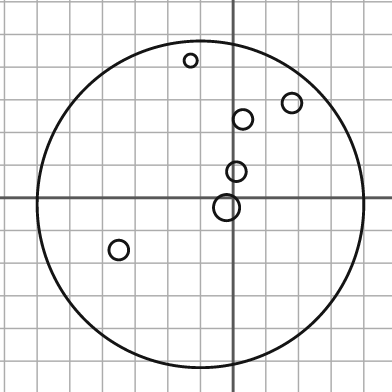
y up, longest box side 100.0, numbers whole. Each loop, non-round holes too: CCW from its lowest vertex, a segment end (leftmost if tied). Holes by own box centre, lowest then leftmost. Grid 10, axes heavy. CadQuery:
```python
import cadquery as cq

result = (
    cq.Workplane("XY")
    .moveTo(-10.0, -2.0)
    .circle(50.0)
    .moveTo(-35.0, -16.0)
    .circle(3.0)
    .moveTo(-2.0, -3.0)
    .circle(4.0)
    .moveTo(1.0, 8.0)
    .circle(3.0)
    .moveTo(3.0, 24.0)
    .circle(3.0)
    .moveTo(18.0, 29.0)
    .circle(3.0)
    .moveTo(-13.0, 42.0)
    .circle(2.0)
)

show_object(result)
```